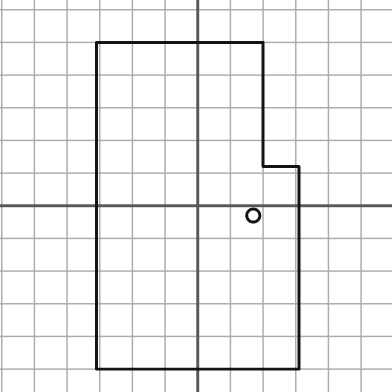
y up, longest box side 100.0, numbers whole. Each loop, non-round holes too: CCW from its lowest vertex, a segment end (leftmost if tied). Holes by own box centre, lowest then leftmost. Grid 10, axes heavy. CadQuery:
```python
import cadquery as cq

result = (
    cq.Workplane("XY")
    .moveTo(-31.0, -50.0)
    .lineTo(31.0, -50.0)
    .lineTo(31.0, 12.0)
    .lineTo(20.0, 12.0)
    .lineTo(20.0, 50.0)
    .lineTo(-31.0, 50.0)
    .close()
    .moveTo(17.0, -3.0)
    .circle(2.0)
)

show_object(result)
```